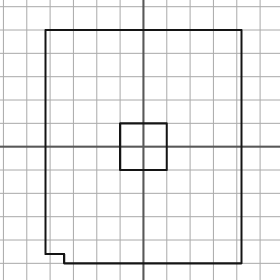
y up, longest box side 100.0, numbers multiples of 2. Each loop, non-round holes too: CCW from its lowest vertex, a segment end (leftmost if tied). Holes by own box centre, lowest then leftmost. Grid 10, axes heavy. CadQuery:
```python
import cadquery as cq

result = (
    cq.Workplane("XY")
    .moveTo(-34.0, -50.0)
    .lineTo(42.0, -50.0)
    .lineTo(42.0, 50.0)
    .lineTo(-42.0, 50.0)
    .lineTo(-42.0, -46.0)
    .lineTo(-34.0, -46.0)
    .close()
    .moveTo(-10.0, -10.0)
    .lineTo(10.0, -10.0)
    .lineTo(10.0, 10.0)
    .lineTo(-10.0, 10.0)
    .close()
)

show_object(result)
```